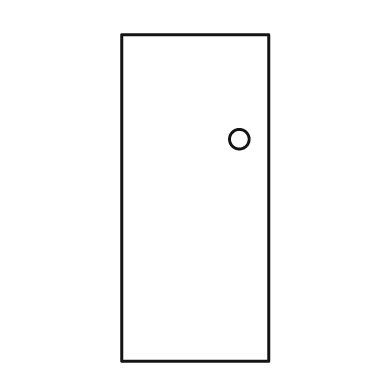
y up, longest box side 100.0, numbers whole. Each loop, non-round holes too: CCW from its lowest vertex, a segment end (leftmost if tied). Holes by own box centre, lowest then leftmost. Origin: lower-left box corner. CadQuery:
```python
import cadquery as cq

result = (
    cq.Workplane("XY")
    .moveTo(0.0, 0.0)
    .lineTo(45.0, 0.0)
    .lineTo(45.0, 100.0)
    .lineTo(0.0, 100.0)
    .close()
    .moveTo(36.0, 68.0)
    .circle(3.0)
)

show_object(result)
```